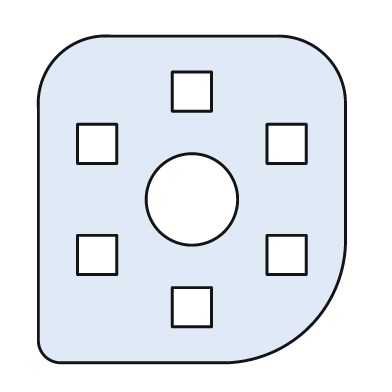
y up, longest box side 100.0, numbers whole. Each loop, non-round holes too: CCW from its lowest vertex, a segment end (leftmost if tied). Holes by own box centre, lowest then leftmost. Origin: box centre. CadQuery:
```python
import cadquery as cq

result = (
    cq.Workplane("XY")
    .moveTo(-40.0, -50.0)
    .lineTo(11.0, -50.0)
    .threePointArc((36.0, -39.0), (47.0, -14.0))
    .lineTo(47.0, 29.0)
    .threePointArc((41.0, 44.0), (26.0, 50.0))
    .lineTo(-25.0, 50.0)
    .threePointArc((-41.0, 44.0), (-47.0, 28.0))
    .lineTo(-47.0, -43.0)
    .threePointArc((-45.0, -48.0), (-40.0, -50.0))
    .close()
    .moveTo(-6.0, -39.0)
    .lineTo(6.0, -39.0)
    .lineTo(6.0, -27.0)
    .lineTo(-6.0, -27.0)
    .close()
    .moveTo(-35.0, -23.0)
    .lineTo(-23.0, -23.0)
    .lineTo(-23.0, -11.0)
    .lineTo(-35.0, -11.0)
    .close()
    .moveTo(23.0, -23.0)
    .lineTo(35.0, -23.0)
    .lineTo(35.0, -11.0)
    .lineTo(23.0, -11.0)
    .close()
    .moveTo(0.0, 0.0)
    .circle(14.0)
    .moveTo(-35.0, 11.0)
    .lineTo(-23.0, 11.0)
    .lineTo(-23.0, 23.0)
    .lineTo(-35.0, 23.0)
    .close()
    .moveTo(23.0, 11.0)
    .lineTo(35.0, 11.0)
    .lineTo(35.0, 23.0)
    .lineTo(23.0, 23.0)
    .close()
    .moveTo(-6.0, 27.0)
    .lineTo(6.0, 27.0)
    .lineTo(6.0, 39.0)
    .lineTo(-6.0, 39.0)
    .close()
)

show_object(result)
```